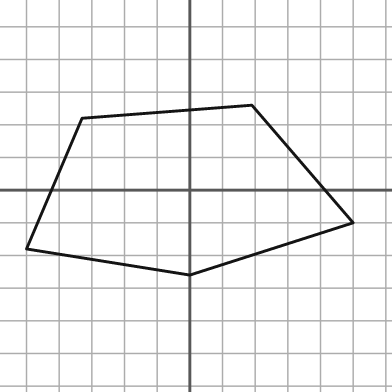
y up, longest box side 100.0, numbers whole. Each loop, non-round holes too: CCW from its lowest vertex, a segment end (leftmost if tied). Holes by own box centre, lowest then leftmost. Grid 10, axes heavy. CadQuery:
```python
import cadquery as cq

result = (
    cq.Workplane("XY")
    .moveTo(0.0, -26.0)
    .lineTo(50.0, -10.0)
    .lineTo(19.0, 26.0)
    .lineTo(-33.0, 22.0)
    .lineTo(-50.0, -18.0)
    .close()
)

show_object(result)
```